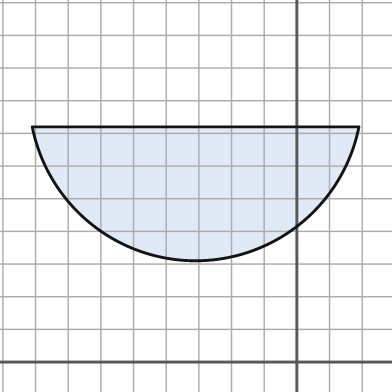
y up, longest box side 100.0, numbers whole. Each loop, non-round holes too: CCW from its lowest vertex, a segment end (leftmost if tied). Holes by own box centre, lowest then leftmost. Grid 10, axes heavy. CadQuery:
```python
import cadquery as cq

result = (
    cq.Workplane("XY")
    .moveTo(-81.0, 72.0)
    .threePointArc((-31.0, 31.0), (19.0, 72.0))
    .close()
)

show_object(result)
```